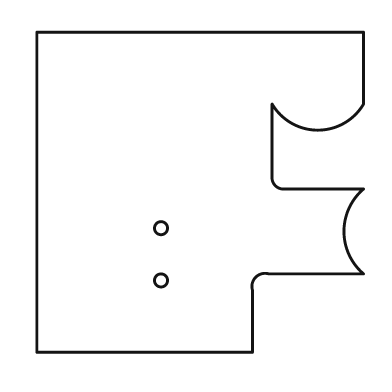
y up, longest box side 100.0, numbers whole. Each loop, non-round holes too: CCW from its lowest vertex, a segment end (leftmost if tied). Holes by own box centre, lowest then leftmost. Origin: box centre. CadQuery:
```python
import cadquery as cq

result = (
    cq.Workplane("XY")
    .moveTo(-50.0, -49.0)
    .lineTo(16.0, -49.0)
    .lineTo(16.0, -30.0)
    .threePointArc((17.0, -26.0), (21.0, -25.0))
    .lineTo(50.0, -25.0)
    .threePointArc((44.0, -12.0), (50.0, 1.0))
    .lineTo(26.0, 1.0)
    .threePointArc((23.0, 2.0), (22.0, 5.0))
    .lineTo(22.0, 27.0)
    .threePointArc((36.0, 19.0), (50.0, 27.0))
    .lineTo(50.0, 49.0)
    .lineTo(-50.0, 49.0)
    .close()
    .moveTo(-12.0, -27.0)
    .circle(2.0)
    .moveTo(-12.0, -11.0)
    .circle(2.0)
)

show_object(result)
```